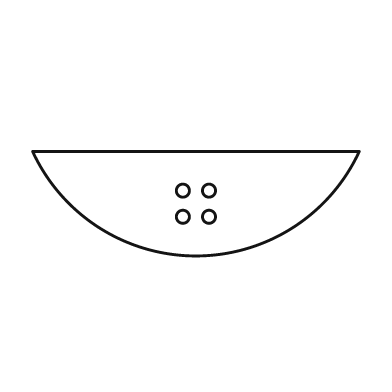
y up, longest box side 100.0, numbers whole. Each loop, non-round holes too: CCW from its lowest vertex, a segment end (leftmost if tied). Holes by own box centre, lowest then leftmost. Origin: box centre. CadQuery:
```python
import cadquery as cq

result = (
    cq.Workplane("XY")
    .moveTo(-50.0, 16.0)
    .threePointArc((0.0, -16.0), (50.0, 16.0))
    .close()
    .moveTo(-4.0, -4.0)
    .circle(2.0)
    .moveTo(4.0, -4.0)
    .circle(2.0)
    .moveTo(-4.0, 4.0)
    .circle(2.0)
    .moveTo(4.0, 4.0)
    .circle(2.0)
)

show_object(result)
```